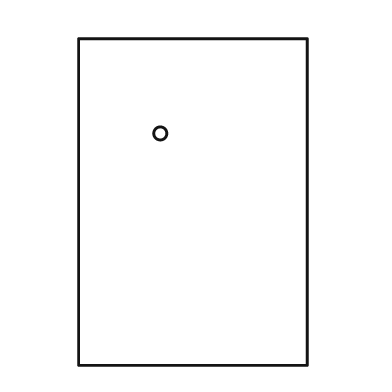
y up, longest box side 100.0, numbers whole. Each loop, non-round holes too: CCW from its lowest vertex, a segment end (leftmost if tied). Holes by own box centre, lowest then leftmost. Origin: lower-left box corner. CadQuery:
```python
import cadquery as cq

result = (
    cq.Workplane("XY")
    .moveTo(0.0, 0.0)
    .lineTo(70.0, 0.0)
    .lineTo(70.0, 100.0)
    .lineTo(0.0, 100.0)
    .close()
    .moveTo(25.0, 71.0)
    .circle(2.0)
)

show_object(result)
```